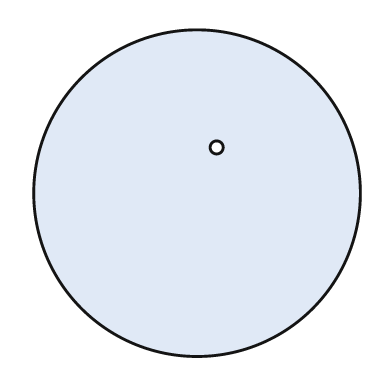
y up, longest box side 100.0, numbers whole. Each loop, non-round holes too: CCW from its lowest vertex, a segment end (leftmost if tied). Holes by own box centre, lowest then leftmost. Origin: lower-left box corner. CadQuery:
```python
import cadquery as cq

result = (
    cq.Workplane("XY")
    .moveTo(50.0, 50.0)
    .circle(50.0)
    .moveTo(56.0, 64.0)
    .circle(2.0)
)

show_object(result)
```